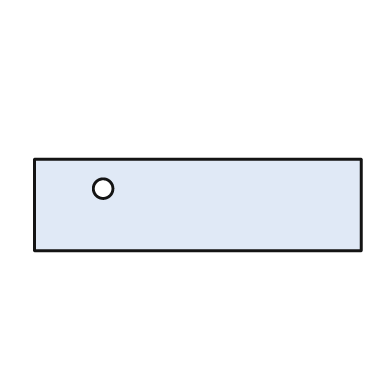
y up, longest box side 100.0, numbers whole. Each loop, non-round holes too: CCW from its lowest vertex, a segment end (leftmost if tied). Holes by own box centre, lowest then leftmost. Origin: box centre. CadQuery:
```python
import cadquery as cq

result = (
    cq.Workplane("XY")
    .moveTo(-50.0, -14.0)
    .lineTo(50.0, -14.0)
    .lineTo(50.0, 14.0)
    .lineTo(-50.0, 14.0)
    .close()
    .moveTo(-29.0, 5.0)
    .circle(3.0)
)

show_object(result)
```